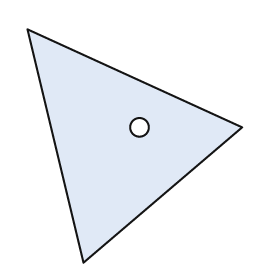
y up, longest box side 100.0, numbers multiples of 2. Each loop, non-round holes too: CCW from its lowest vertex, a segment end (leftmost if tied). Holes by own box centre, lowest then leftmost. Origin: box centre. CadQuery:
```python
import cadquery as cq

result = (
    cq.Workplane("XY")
    .moveTo(-22.0, -50.0)
    .lineTo(46.0, 8.0)
    .lineTo(-46.0, 50.0)
    .close()
    .moveTo(2.0, 8.0)
    .circle(4.0)
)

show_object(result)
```